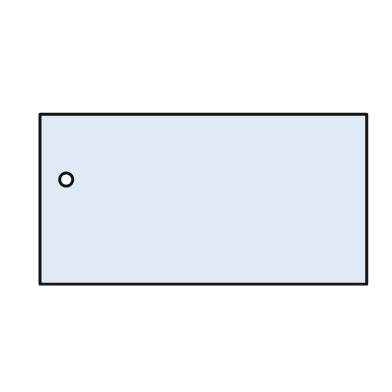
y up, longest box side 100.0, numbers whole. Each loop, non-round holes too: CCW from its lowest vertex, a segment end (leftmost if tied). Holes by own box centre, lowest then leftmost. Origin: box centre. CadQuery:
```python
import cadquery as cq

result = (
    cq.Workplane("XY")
    .moveTo(-50.0, -26.0)
    .lineTo(50.0, -26.0)
    .lineTo(50.0, 26.0)
    .lineTo(-50.0, 26.0)
    .close()
    .moveTo(-42.0, 6.0)
    .circle(2.0)
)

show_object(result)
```